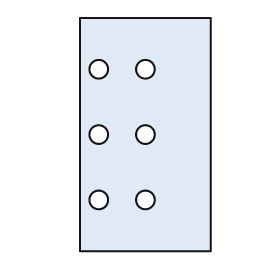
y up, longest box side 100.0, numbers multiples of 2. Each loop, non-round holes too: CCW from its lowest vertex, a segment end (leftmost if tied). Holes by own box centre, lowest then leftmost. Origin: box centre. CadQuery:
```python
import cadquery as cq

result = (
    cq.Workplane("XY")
    .moveTo(-28.0, -50.0)
    .lineTo(28.0, -50.0)
    .lineTo(28.0, 50.0)
    .lineTo(-28.0, 50.0)
    .close()
    .moveTo(-20.0, -28.0)
    .circle(4.0)
    .moveTo(0.0, -28.0)
    .circle(4.0)
    .moveTo(-20.0, 0.0)
    .circle(4.0)
    .moveTo(0.0, 0.0)
    .circle(4.0)
    .moveTo(-20.0, 28.0)
    .circle(4.0)
    .moveTo(0.0, 28.0)
    .circle(4.0)
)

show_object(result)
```